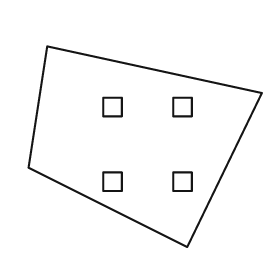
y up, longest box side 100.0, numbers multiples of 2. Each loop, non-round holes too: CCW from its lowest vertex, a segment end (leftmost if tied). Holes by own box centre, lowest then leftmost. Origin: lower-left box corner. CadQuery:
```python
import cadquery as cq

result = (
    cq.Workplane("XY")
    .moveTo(68.0, 0.0)
    .lineTo(100.0, 66.0)
    .lineTo(8.0, 86.0)
    .lineTo(0.0, 34.0)
    .close()
    .moveTo(32.0, 24.0)
    .lineTo(40.0, 24.0)
    .lineTo(40.0, 32.0)
    .lineTo(32.0, 32.0)
    .close()
    .moveTo(62.0, 24.0)
    .lineTo(70.0, 24.0)
    .lineTo(70.0, 32.0)
    .lineTo(62.0, 32.0)
    .close()
    .moveTo(32.0, 56.0)
    .lineTo(40.0, 56.0)
    .lineTo(40.0, 64.0)
    .lineTo(32.0, 64.0)
    .close()
    .moveTo(62.0, 56.0)
    .lineTo(70.0, 56.0)
    .lineTo(70.0, 64.0)
    .lineTo(62.0, 64.0)
    .close()
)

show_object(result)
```